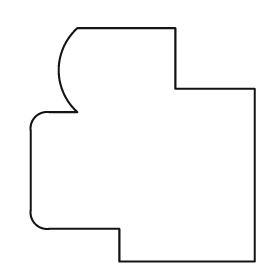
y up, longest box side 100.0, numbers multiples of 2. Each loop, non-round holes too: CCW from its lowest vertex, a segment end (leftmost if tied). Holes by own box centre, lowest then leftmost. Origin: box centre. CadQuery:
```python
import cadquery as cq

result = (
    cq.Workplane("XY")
    .moveTo(-10.0, -50.0)
    .lineTo(48.0, -50.0)
    .lineTo(48.0, 24.0)
    .lineTo(14.0, 24.0)
    .lineTo(14.0, 50.0)
    .lineTo(-28.0, 50.0)
    .threePointArc((-36.0, 32.0), (-28.0, 14.0))
    .lineTo(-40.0, 14.0)
    .threePointArc((-46.0, 12.0), (-48.0, 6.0))
    .lineTo(-48.0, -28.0)
    .threePointArc((-46.0, -34.0), (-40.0, -36.0))
    .lineTo(-10.0, -36.0)
    .close()
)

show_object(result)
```